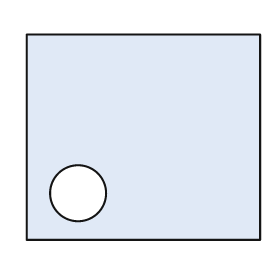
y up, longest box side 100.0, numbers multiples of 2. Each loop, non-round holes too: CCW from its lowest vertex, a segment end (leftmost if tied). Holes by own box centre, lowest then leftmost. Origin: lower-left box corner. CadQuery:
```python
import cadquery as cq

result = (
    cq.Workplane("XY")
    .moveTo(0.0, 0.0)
    .lineTo(100.0, 0.0)
    .lineTo(100.0, 88.0)
    .lineTo(0.0, 88.0)
    .close()
    .moveTo(22.0, 20.0)
    .circle(12.0)
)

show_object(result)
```